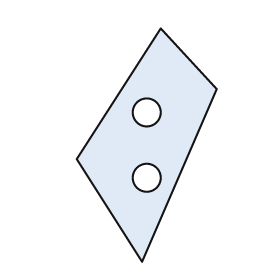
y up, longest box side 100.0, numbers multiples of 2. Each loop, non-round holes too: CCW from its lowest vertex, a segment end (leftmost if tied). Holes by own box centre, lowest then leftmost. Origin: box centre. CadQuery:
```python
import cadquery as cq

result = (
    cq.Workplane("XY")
    .moveTo(-2.0, -50.0)
    .lineTo(30.0, 24.0)
    .lineTo(6.0, 50.0)
    .lineTo(-30.0, -6.0)
    .close()
    .moveTo(0.0, -14.0)
    .circle(6.0)
    .moveTo(0.0, 14.0)
    .circle(6.0)
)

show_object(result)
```